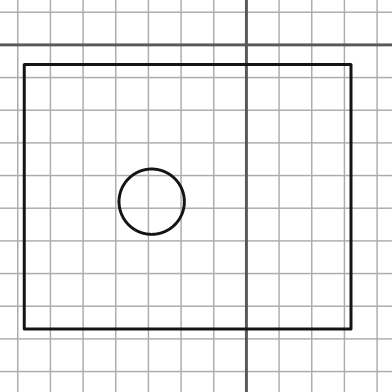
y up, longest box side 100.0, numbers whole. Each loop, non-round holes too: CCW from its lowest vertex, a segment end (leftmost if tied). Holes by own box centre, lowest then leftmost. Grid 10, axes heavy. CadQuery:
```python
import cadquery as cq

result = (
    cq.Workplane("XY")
    .moveTo(-68.0, -87.0)
    .lineTo(32.0, -87.0)
    .lineTo(32.0, -6.0)
    .lineTo(-68.0, -6.0)
    .close()
    .moveTo(-29.0, -48.0)
    .circle(10.0)
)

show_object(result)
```